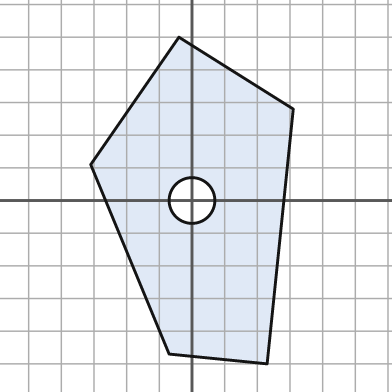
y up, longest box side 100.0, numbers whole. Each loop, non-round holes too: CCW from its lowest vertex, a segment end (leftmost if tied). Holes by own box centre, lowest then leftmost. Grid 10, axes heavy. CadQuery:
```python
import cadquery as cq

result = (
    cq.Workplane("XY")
    .moveTo(23.0, -50.0)
    .lineTo(31.0, 28.0)
    .lineTo(-4.0, 50.0)
    .lineTo(-31.0, 11.0)
    .lineTo(-7.0, -47.0)
    .close()
    .moveTo(0.0, 0.0)
    .circle(7.0)
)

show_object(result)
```